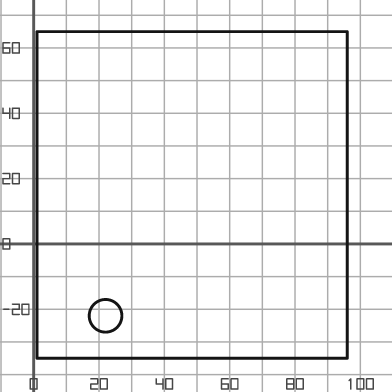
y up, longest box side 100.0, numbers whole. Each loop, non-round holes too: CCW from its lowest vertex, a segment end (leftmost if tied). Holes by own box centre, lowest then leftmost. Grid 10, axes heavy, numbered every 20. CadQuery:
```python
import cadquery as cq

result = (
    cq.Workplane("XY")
    .moveTo(1.0, -35.0)
    .lineTo(96.0, -35.0)
    .lineTo(96.0, 65.0)
    .lineTo(1.0, 65.0)
    .close()
    .moveTo(22.0, -22.0)
    .circle(5.0)
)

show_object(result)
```